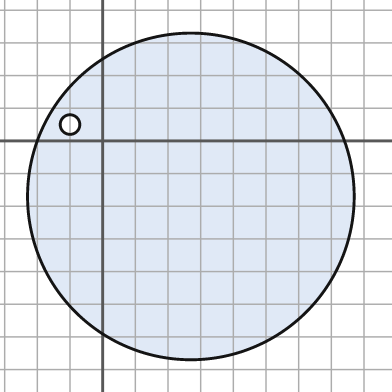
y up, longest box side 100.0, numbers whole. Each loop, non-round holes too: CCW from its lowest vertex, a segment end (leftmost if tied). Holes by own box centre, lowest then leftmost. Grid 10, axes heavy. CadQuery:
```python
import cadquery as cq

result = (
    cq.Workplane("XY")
    .moveTo(27.0, -17.0)
    .circle(50.0)
    .moveTo(-10.0, 5.0)
    .circle(3.0)
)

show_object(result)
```